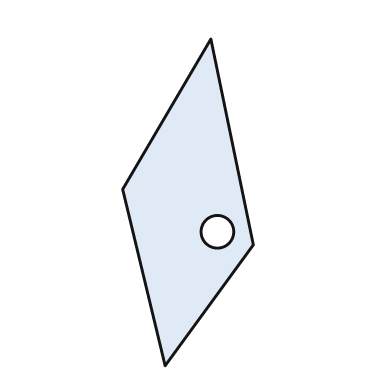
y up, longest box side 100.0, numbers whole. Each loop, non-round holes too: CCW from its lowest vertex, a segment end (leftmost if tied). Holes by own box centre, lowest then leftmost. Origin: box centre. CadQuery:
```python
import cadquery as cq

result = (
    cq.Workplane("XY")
    .moveTo(-7.0, -50.0)
    .lineTo(20.0, -13.0)
    .lineTo(7.0, 50.0)
    .lineTo(-20.0, 4.0)
    .close()
    .moveTo(9.0, -9.0)
    .circle(5.0)
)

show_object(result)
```